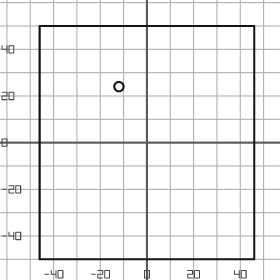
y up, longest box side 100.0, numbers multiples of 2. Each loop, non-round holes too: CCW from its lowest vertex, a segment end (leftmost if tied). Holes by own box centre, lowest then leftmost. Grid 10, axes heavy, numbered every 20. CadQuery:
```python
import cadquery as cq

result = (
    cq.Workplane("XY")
    .moveTo(-46.0, -50.0)
    .lineTo(46.0, -50.0)
    .lineTo(46.0, 50.0)
    .lineTo(-46.0, 50.0)
    .close()
    .moveTo(-12.0, 24.0)
    .circle(2.0)
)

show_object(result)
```